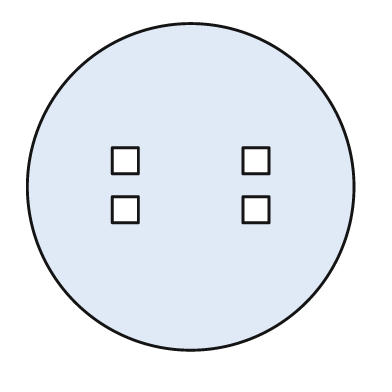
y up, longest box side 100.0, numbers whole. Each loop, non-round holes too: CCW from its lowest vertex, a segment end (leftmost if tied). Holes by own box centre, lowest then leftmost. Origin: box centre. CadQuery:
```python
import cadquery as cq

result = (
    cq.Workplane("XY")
    .moveTo(0.0, 0.0)
    .circle(50.0)
    .moveTo(-24.0, -11.0)
    .lineTo(-16.0, -11.0)
    .lineTo(-16.0, -3.0)
    .lineTo(-24.0, -3.0)
    .close()
    .moveTo(16.0, -11.0)
    .lineTo(24.0, -11.0)
    .lineTo(24.0, -3.0)
    .lineTo(16.0, -3.0)
    .close()
    .moveTo(-24.0, 4.0)
    .lineTo(-16.0, 4.0)
    .lineTo(-16.0, 12.0)
    .lineTo(-24.0, 12.0)
    .close()
    .moveTo(16.0, 4.0)
    .lineTo(24.0, 4.0)
    .lineTo(24.0, 12.0)
    .lineTo(16.0, 12.0)
    .close()
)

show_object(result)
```